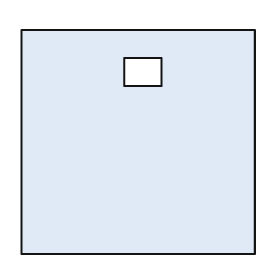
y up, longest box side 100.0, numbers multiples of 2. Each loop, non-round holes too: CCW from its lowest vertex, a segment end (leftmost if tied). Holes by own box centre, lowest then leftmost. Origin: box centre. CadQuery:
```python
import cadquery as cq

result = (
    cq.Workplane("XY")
    .moveTo(-50.0, -48.0)
    .lineTo(50.0, -48.0)
    .lineTo(50.0, 48.0)
    .lineTo(-50.0, 48.0)
    .close()
    .moveTo(-6.0, 24.0)
    .lineTo(10.0, 24.0)
    .lineTo(10.0, 36.0)
    .lineTo(-6.0, 36.0)
    .close()
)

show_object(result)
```